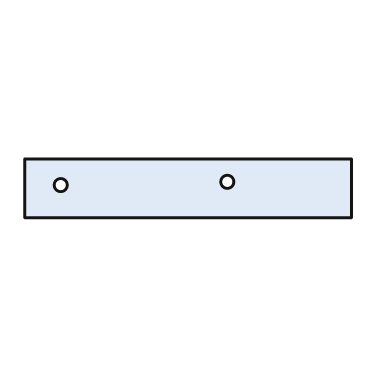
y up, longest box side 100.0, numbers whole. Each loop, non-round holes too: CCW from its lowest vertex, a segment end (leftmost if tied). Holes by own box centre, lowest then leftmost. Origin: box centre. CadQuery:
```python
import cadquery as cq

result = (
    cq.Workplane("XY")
    .moveTo(-50.0, -9.0)
    .lineTo(50.0, -9.0)
    .lineTo(50.0, 9.0)
    .lineTo(-50.0, 9.0)
    .close()
    .moveTo(-39.0, 1.0)
    .circle(2.0)
    .moveTo(12.0, 2.0)
    .circle(2.0)
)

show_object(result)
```